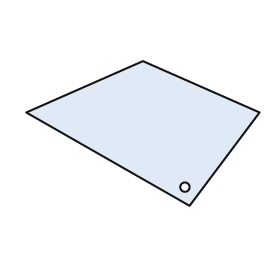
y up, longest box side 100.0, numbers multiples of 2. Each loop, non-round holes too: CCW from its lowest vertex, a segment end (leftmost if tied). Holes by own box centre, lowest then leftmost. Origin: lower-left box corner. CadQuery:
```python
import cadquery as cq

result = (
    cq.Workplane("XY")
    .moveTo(70.0, 0.0)
    .lineTo(100.0, 40.0)
    .lineTo(50.0, 62.0)
    .lineTo(0.0, 40.0)
    .close()
    .moveTo(68.0, 8.0)
    .circle(2.0)
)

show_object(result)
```